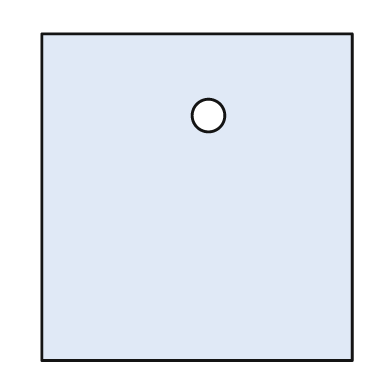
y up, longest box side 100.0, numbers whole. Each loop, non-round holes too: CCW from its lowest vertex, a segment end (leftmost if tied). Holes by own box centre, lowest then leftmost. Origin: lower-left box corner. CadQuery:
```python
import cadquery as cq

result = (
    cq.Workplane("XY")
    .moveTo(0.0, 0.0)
    .lineTo(95.0, 0.0)
    .lineTo(95.0, 100.0)
    .lineTo(0.0, 100.0)
    .close()
    .moveTo(51.0, 75.0)
    .circle(5.0)
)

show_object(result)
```